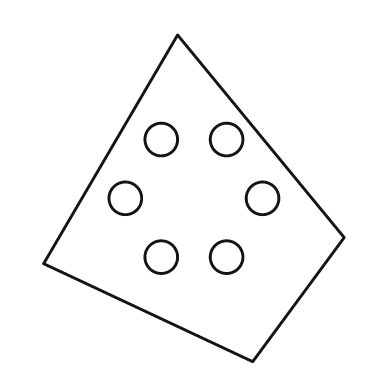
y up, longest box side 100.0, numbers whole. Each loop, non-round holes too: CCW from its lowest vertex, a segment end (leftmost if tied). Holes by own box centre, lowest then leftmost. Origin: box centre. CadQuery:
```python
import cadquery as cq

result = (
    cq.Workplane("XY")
    .moveTo(18.0, -50.0)
    .lineTo(46.0, -12.0)
    .lineTo(-5.0, 50.0)
    .lineTo(-46.0, -20.0)
    .close()
    .moveTo(-10.0, -18.0)
    .circle(5.0)
    .moveTo(10.0, -18.0)
    .circle(5.0)
    .moveTo(-21.0, 0.0)
    .circle(5.0)
    .moveTo(21.0, 0.0)
    .circle(5.0)
    .moveTo(-10.0, 18.0)
    .circle(5.0)
    .moveTo(10.0, 18.0)
    .circle(5.0)
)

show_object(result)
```